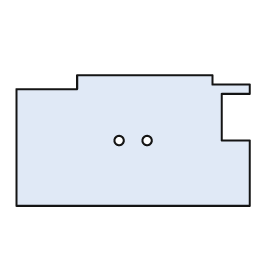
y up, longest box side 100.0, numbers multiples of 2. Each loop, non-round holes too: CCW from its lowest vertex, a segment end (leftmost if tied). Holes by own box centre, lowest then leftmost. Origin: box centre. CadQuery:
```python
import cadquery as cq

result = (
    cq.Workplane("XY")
    .moveTo(-50.0, -28.0)
    .lineTo(50.0, -28.0)
    .lineTo(50.0, 0.0)
    .lineTo(38.0, 0.0)
    .lineTo(38.0, 20.0)
    .lineTo(50.0, 20.0)
    .lineTo(50.0, 24.0)
    .lineTo(34.0, 24.0)
    .lineTo(34.0, 28.0)
    .lineTo(-24.0, 28.0)
    .lineTo(-24.0, 22.0)
    .lineTo(-50.0, 22.0)
    .close()
    .moveTo(-6.0, 0.0)
    .circle(2.0)
    .moveTo(6.0, 0.0)
    .circle(2.0)
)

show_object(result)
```